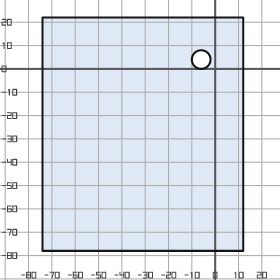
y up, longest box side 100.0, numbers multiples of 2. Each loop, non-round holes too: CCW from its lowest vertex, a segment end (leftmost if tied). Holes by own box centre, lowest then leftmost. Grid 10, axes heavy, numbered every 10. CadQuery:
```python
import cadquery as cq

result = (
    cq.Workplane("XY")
    .moveTo(-74.0, -78.0)
    .lineTo(12.0, -78.0)
    .lineTo(12.0, 22.0)
    .lineTo(-74.0, 22.0)
    .close()
    .moveTo(-6.0, 4.0)
    .circle(4.0)
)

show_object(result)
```